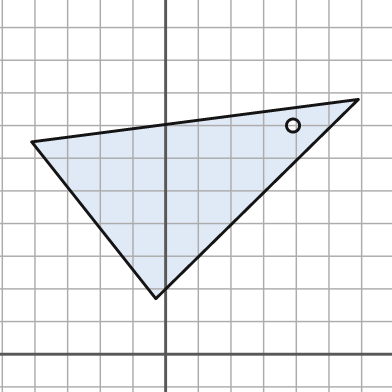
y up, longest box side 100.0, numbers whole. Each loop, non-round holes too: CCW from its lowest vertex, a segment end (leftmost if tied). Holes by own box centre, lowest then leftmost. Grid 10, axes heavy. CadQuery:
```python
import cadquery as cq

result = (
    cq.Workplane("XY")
    .moveTo(-3.0, 17.0)
    .lineTo(59.0, 78.0)
    .lineTo(-41.0, 65.0)
    .close()
    .moveTo(39.0, 70.0)
    .circle(2.0)
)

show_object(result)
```